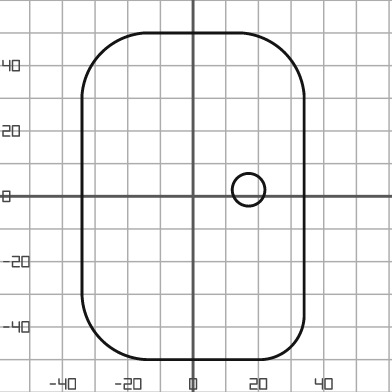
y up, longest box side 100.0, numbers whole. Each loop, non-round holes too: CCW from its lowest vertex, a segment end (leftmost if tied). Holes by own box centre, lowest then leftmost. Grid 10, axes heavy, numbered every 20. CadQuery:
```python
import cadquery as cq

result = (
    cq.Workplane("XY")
    .moveTo(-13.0, -50.0)
    .lineTo(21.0, -50.0)
    .threePointArc((30.0, -46.0), (34.0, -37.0))
    .lineTo(34.0, 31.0)
    .threePointArc((28.0, 44.0), (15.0, 50.0))
    .lineTo(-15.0, 50.0)
    .threePointArc((-28.0, 44.0), (-34.0, 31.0))
    .lineTo(-34.0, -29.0)
    .threePointArc((-28.0, -44.0), (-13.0, -50.0))
    .close()
    .moveTo(17.0, 2.0)
    .circle(5.0)
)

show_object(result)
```